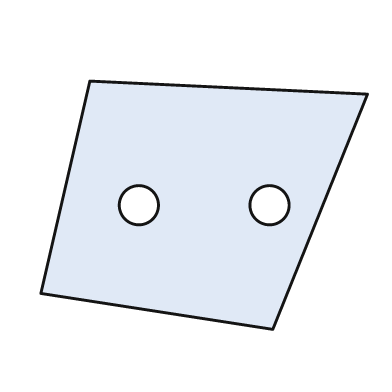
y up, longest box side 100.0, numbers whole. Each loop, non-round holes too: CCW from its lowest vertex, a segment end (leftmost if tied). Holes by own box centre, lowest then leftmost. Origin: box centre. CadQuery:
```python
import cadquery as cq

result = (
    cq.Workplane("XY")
    .moveTo(21.0, -38.0)
    .lineTo(50.0, 34.0)
    .lineTo(-35.0, 38.0)
    .lineTo(-50.0, -27.0)
    .close()
    .moveTo(-20.0, 0.0)
    .circle(6.0)
    .moveTo(20.0, 0.0)
    .circle(6.0)
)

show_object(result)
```